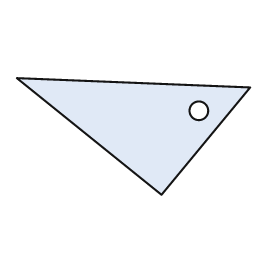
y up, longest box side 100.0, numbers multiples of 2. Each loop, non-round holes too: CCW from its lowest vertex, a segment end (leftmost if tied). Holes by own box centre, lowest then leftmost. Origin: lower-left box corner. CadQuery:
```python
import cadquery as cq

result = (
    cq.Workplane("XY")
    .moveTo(62.0, 0.0)
    .lineTo(100.0, 46.0)
    .lineTo(0.0, 50.0)
    .close()
    .moveTo(78.0, 36.0)
    .circle(4.0)
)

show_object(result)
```